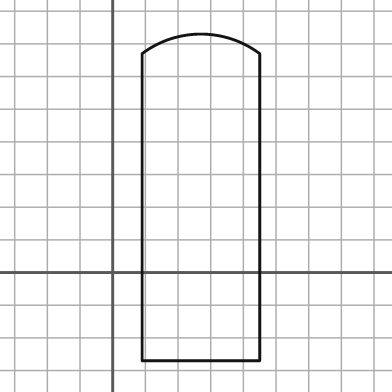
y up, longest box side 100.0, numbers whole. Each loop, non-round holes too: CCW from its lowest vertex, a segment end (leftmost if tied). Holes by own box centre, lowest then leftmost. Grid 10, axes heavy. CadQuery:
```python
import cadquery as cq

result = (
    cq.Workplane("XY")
    .moveTo(9.0, -27.0)
    .lineTo(45.0, -27.0)
    .lineTo(45.0, 67.0)
    .threePointArc((27.0, 73.0), (9.0, 67.0))
    .close()
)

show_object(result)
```